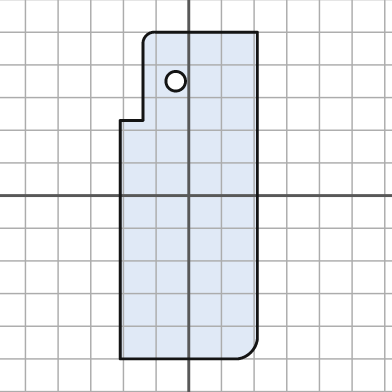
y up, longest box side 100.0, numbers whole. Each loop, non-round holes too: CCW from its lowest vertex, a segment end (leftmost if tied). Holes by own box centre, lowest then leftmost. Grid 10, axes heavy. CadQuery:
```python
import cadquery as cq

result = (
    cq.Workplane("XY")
    .moveTo(-21.0, -50.0)
    .lineTo(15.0, -50.0)
    .threePointArc((19.0, -48.0), (21.0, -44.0))
    .lineTo(21.0, 50.0)
    .lineTo(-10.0, 50.0)
    .threePointArc((-13.0, 49.0), (-14.0, 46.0))
    .lineTo(-14.0, 23.0)
    .lineTo(-21.0, 23.0)
    .close()
    .moveTo(-4.0, 35.0)
    .circle(3.0)
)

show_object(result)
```